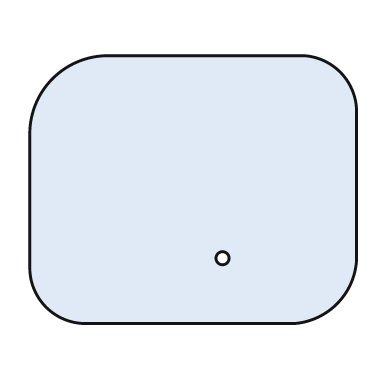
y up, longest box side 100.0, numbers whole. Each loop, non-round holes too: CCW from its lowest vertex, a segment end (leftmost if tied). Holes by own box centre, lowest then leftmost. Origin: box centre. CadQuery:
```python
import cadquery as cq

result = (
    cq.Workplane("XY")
    .moveTo(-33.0, -41.0)
    .lineTo(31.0, -41.0)
    .threePointArc((44.0, -35.0), (50.0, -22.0))
    .lineTo(50.0, 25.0)
    .threePointArc((45.0, 36.0), (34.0, 41.0))
    .lineTo(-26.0, 41.0)
    .threePointArc((-43.0, 34.0), (-50.0, 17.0))
    .lineTo(-50.0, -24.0)
    .threePointArc((-45.0, -36.0), (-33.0, -41.0))
    .close()
    .moveTo(9.0, -21.0)
    .circle(2.0)
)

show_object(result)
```